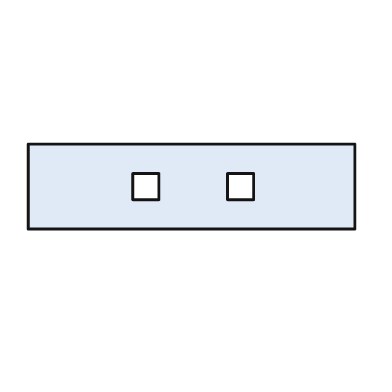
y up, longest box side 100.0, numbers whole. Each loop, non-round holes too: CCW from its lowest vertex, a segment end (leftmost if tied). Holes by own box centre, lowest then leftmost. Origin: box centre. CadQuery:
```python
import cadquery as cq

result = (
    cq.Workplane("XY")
    .moveTo(-50.0, -13.0)
    .lineTo(50.0, -13.0)
    .lineTo(50.0, 13.0)
    .lineTo(-50.0, 13.0)
    .close()
    .moveTo(-18.0, -4.0)
    .lineTo(-10.0, -4.0)
    .lineTo(-10.0, 4.0)
    .lineTo(-18.0, 4.0)
    .close()
    .moveTo(11.0, -4.0)
    .lineTo(19.0, -4.0)
    .lineTo(19.0, 4.0)
    .lineTo(11.0, 4.0)
    .close()
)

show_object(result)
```